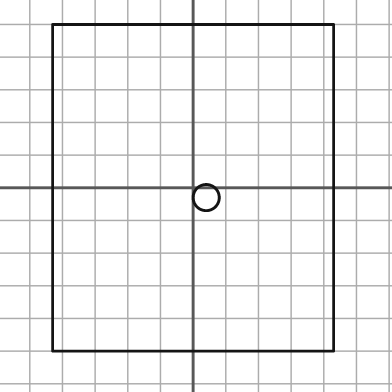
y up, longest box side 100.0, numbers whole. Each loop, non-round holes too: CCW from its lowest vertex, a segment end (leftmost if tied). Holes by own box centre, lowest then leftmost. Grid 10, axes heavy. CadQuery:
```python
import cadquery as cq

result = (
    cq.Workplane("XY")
    .moveTo(-43.0, -50.0)
    .lineTo(43.0, -50.0)
    .lineTo(43.0, 50.0)
    .lineTo(-43.0, 50.0)
    .close()
    .moveTo(4.0, -3.0)
    .circle(4.0)
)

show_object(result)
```